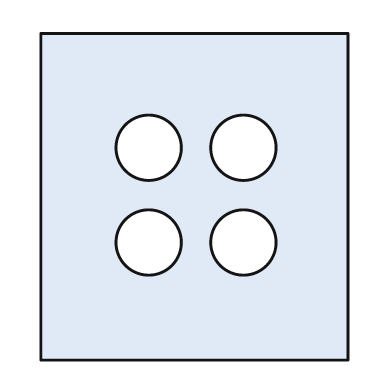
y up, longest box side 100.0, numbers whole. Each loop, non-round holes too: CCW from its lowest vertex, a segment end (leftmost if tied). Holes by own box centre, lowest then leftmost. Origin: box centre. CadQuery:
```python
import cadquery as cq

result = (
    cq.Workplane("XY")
    .moveTo(-47.0, -50.0)
    .lineTo(47.0, -50.0)
    .lineTo(47.0, 50.0)
    .lineTo(-47.0, 50.0)
    .close()
    .moveTo(-14.0, -14.0)
    .circle(10.0)
    .moveTo(15.0, -14.0)
    .circle(10.0)
    .moveTo(-14.0, 15.0)
    .circle(10.0)
    .moveTo(15.0, 15.0)
    .circle(10.0)
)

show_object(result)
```